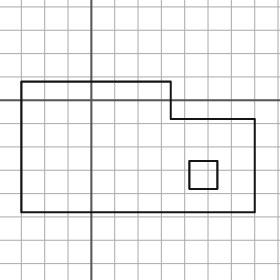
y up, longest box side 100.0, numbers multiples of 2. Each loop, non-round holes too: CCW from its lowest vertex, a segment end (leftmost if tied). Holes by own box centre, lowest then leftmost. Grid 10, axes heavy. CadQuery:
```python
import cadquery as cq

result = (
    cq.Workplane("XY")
    .moveTo(-30.0, -48.0)
    .lineTo(70.0, -48.0)
    .lineTo(70.0, -8.0)
    .lineTo(34.0, -8.0)
    .lineTo(34.0, 8.0)
    .lineTo(-30.0, 8.0)
    .close()
    .moveTo(42.0, -38.0)
    .lineTo(54.0, -38.0)
    .lineTo(54.0, -26.0)
    .lineTo(42.0, -26.0)
    .close()
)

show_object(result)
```